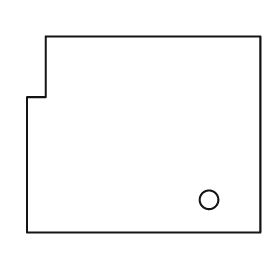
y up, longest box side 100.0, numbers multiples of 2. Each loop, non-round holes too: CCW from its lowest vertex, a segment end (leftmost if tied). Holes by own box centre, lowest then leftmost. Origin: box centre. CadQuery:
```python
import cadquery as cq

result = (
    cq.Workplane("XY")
    .moveTo(-50.0, -42.0)
    .lineTo(50.0, -42.0)
    .lineTo(50.0, 42.0)
    .lineTo(-42.0, 42.0)
    .lineTo(-42.0, 16.0)
    .lineTo(-50.0, 16.0)
    .close()
    .moveTo(28.0, -28.0)
    .circle(4.0)
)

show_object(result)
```